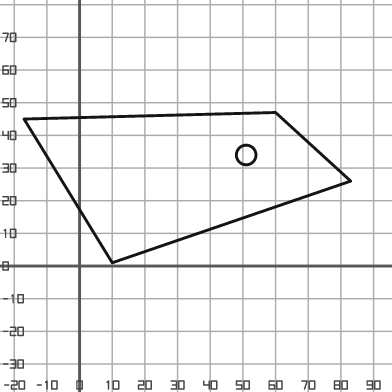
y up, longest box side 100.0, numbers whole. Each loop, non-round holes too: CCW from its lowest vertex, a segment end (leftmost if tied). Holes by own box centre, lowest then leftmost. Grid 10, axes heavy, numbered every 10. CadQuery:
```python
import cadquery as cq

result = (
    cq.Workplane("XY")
    .moveTo(10.0, 1.0)
    .lineTo(83.0, 26.0)
    .lineTo(60.0, 47.0)
    .lineTo(-17.0, 45.0)
    .close()
    .moveTo(51.0, 34.0)
    .circle(3.0)
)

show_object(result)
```